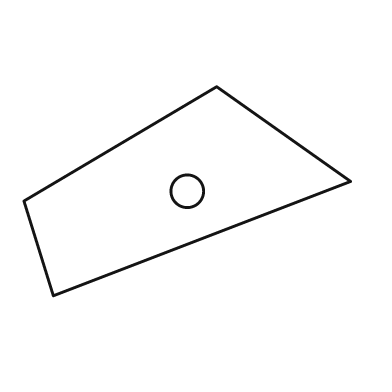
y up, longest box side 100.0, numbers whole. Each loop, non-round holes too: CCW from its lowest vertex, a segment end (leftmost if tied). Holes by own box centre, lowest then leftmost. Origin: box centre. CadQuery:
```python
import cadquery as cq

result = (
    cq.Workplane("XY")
    .moveTo(-41.0, -32.0)
    .lineTo(50.0, 3.0)
    .lineTo(9.0, 32.0)
    .lineTo(-50.0, -3.0)
    .close()
    .moveTo(0.0, 0.0)
    .circle(5.0)
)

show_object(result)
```